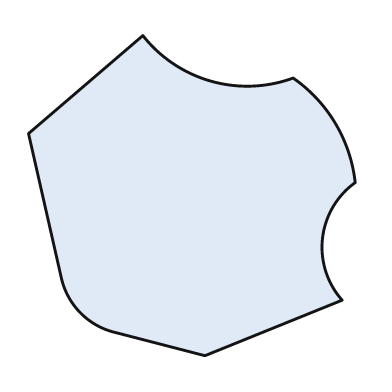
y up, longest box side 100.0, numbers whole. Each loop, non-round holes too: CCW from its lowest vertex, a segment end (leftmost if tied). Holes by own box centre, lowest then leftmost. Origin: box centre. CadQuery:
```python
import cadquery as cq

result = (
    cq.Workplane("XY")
    .moveTo(4.0, -49.0)
    .lineTo(46.0, -32.0)
    .threePointArc((40.0, -13.0), (50.0, 4.0))
    .threePointArc((44.0, 22.0), (31.0, 36.0))
    .threePointArc((6.0, 35.0), (-15.0, 49.0))
    .lineTo(-50.0, 19.0)
    .lineTo(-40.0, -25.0)
    .threePointArc((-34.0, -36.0), (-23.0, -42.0))
    .close()
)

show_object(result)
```